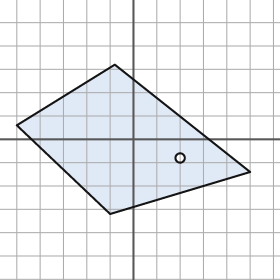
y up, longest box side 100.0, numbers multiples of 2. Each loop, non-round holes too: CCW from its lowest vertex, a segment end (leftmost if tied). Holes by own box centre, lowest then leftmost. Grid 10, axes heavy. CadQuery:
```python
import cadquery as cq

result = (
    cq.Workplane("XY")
    .moveTo(-10.0, -32.0)
    .lineTo(50.0, -14.0)
    .lineTo(-8.0, 32.0)
    .lineTo(-50.0, 6.0)
    .close()
    .moveTo(20.0, -8.0)
    .circle(2.0)
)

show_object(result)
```